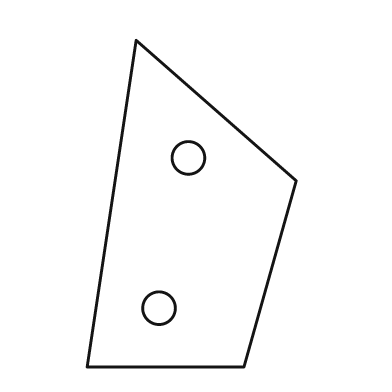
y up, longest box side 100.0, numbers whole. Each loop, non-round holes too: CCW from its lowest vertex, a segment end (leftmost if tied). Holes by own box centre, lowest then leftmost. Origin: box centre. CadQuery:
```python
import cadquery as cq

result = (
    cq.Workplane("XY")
    .moveTo(-32.0, -50.0)
    .lineTo(16.0, -50.0)
    .lineTo(32.0, 7.0)
    .lineTo(-17.0, 50.0)
    .close()
    .moveTo(-10.0, -32.0)
    .circle(5.0)
    .moveTo(-1.0, 14.0)
    .circle(5.0)
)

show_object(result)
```